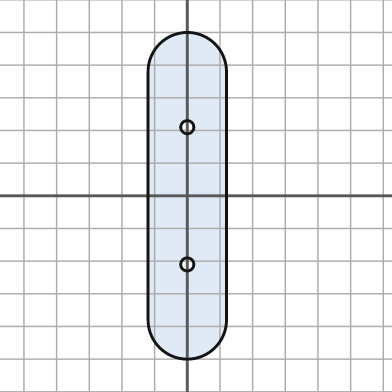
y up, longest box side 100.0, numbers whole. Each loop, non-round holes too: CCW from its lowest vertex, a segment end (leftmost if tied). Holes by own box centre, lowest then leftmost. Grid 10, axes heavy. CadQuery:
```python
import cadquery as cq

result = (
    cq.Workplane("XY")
    .moveTo(-12.0, -38.0)
    .threePointArc((0.0, -50.0), (12.0, -38.0))
    .lineTo(12.0, 38.0)
    .threePointArc((0.0, 50.0), (-12.0, 38.0))
    .close()
    .moveTo(0.0, -21.0)
    .circle(2.0)
    .moveTo(0.0, 21.0)
    .circle(2.0)
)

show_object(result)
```